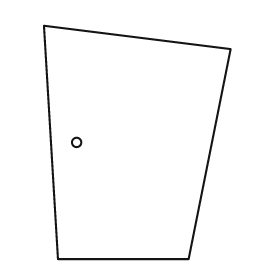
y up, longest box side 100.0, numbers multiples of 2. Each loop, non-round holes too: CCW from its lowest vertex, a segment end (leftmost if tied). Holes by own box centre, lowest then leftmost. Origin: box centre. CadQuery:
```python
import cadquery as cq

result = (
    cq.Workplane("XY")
    .moveTo(-34.0, -50.0)
    .lineTo(22.0, -50.0)
    .lineTo(40.0, 40.0)
    .lineTo(-40.0, 50.0)
    .close()
    .moveTo(-26.0, 0.0)
    .circle(2.0)
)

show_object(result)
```